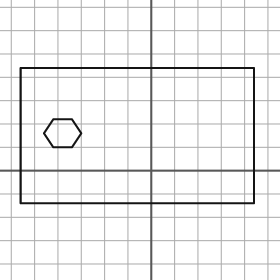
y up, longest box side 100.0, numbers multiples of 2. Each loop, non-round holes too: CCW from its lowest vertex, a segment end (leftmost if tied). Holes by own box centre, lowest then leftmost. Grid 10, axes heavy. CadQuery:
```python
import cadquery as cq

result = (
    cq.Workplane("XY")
    .moveTo(-56.0, -14.0)
    .lineTo(44.0, -14.0)
    .lineTo(44.0, 44.0)
    .lineTo(-56.0, 44.0)
    .close()
    .moveTo(-42.0, 10.0)
    .lineTo(-34.0, 10.0)
    .lineTo(-30.0, 16.0)
    .lineTo(-34.0, 22.0)
    .lineTo(-42.0, 22.0)
    .lineTo(-46.0, 16.0)
    .close()
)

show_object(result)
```